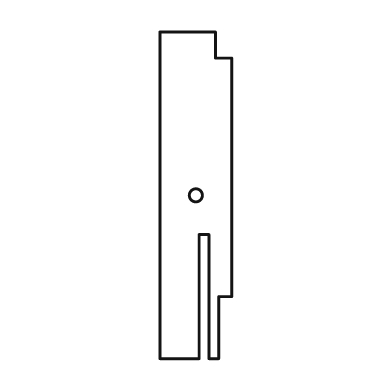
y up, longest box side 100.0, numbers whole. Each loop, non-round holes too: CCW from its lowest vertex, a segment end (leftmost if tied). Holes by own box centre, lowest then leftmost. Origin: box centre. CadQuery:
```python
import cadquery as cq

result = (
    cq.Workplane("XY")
    .moveTo(-11.0, -50.0)
    .lineTo(1.0, -50.0)
    .lineTo(1.0, -12.0)
    .lineTo(4.0, -12.0)
    .lineTo(4.0, -50.0)
    .lineTo(7.0, -50.0)
    .lineTo(7.0, -31.0)
    .lineTo(11.0, -31.0)
    .lineTo(11.0, 42.0)
    .lineTo(6.0, 42.0)
    .lineTo(6.0, 50.0)
    .lineTo(-11.0, 50.0)
    .close()
    .moveTo(0.0, 0.0)
    .circle(2.0)
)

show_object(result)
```